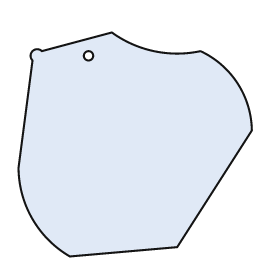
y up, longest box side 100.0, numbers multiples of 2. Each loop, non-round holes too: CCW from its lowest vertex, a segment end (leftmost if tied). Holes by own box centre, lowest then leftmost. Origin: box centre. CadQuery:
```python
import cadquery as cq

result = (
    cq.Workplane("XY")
    .moveTo(-28.0, -48.0)
    .lineTo(18.0, -44.0)
    .lineTo(50.0, 6.0)
    .threePointArc((44.0, 26.0), (28.0, 40.0))
    .threePointArc((8.0, 40.0), (-10.0, 48.0))
    .lineTo(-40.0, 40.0)
    .threePointArc((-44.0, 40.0), (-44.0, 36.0))
    .lineTo(-50.0, -10.0)
    .threePointArc((-44.0, -32.0), (-28.0, -48.0))
    .close()
    .moveTo(-20.0, 38.0)
    .circle(2.0)
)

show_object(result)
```